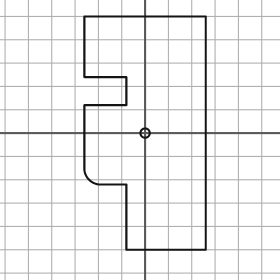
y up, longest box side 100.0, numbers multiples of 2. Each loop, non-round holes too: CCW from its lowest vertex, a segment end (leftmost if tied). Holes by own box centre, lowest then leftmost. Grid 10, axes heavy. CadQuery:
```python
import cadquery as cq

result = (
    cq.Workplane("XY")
    .moveTo(-8.0, -50.0)
    .lineTo(26.0, -50.0)
    .lineTo(26.0, 50.0)
    .lineTo(-26.0, 50.0)
    .lineTo(-26.0, 24.0)
    .lineTo(-8.0, 24.0)
    .lineTo(-8.0, 12.0)
    .lineTo(-26.0, 12.0)
    .lineTo(-26.0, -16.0)
    .threePointArc((-24.0, -20.0), (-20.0, -22.0))
    .lineTo(-8.0, -22.0)
    .close()
    .moveTo(0.0, 0.0)
    .circle(2.0)
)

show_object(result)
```